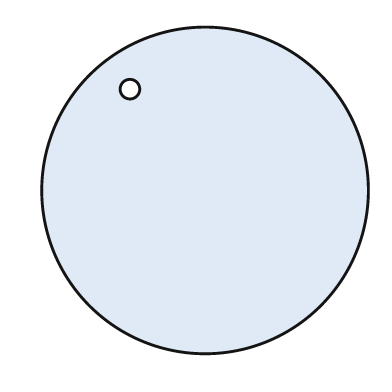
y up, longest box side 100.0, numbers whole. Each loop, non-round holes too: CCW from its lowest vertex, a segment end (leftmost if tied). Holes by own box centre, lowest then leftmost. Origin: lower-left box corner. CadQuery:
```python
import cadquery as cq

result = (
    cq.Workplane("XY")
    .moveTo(50.0, 50.0)
    .circle(50.0)
    .moveTo(27.0, 81.0)
    .circle(3.0)
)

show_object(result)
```